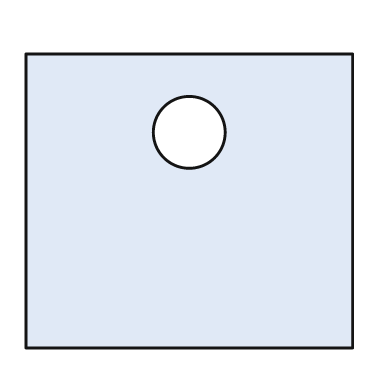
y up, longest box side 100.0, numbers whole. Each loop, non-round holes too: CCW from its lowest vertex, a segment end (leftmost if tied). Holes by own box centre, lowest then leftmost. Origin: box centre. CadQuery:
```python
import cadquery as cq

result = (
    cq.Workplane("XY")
    .moveTo(-50.0, -45.0)
    .lineTo(50.0, -45.0)
    .lineTo(50.0, 45.0)
    .lineTo(-50.0, 45.0)
    .close()
    .moveTo(0.0, 21.0)
    .circle(11.0)
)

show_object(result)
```